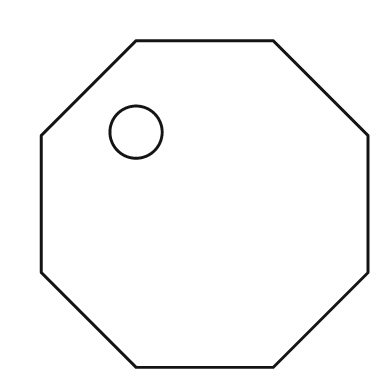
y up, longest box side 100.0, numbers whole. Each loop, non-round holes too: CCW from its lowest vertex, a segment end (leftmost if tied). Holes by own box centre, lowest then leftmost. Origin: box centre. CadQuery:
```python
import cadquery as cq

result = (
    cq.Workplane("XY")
    .moveTo(-21.0, -50.0)
    .lineTo(21.0, -50.0)
    .lineTo(50.0, -21.0)
    .lineTo(50.0, 21.0)
    .lineTo(21.0, 50.0)
    .lineTo(-21.0, 50.0)
    .lineTo(-50.0, 21.0)
    .lineTo(-50.0, -21.0)
    .close()
    .moveTo(-21.0, 22.0)
    .circle(8.0)
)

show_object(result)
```